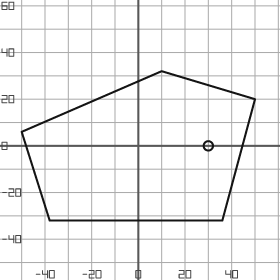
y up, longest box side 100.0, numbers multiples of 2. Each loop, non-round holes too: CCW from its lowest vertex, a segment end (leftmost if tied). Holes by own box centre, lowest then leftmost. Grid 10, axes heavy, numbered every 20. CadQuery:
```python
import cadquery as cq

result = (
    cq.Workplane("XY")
    .moveTo(-38.0, -32.0)
    .lineTo(36.0, -32.0)
    .lineTo(50.0, 20.0)
    .lineTo(10.0, 32.0)
    .lineTo(-50.0, 6.0)
    .close()
    .moveTo(30.0, 0.0)
    .circle(2.0)
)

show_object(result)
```